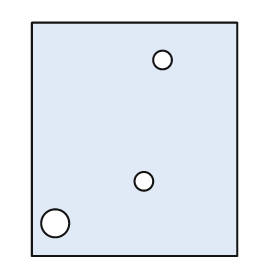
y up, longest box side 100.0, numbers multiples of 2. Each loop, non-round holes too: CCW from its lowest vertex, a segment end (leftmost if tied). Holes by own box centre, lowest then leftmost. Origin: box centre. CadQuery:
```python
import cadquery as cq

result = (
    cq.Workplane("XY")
    .moveTo(-44.0, -50.0)
    .lineTo(44.0, -50.0)
    .lineTo(44.0, 50.0)
    .lineTo(-44.0, 50.0)
    .close()
    .moveTo(-34.0, -36.0)
    .circle(6.0)
    .moveTo(4.0, -18.0)
    .circle(4.0)
    .moveTo(12.0, 34.0)
    .circle(4.0)
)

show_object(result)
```